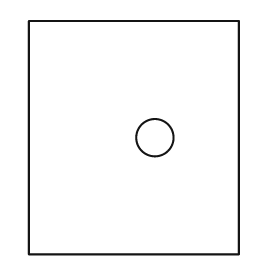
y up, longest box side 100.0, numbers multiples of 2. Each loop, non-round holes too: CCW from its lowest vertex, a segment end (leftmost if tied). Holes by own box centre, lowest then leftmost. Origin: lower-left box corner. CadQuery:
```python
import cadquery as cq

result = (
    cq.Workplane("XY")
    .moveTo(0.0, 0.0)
    .lineTo(90.0, 0.0)
    .lineTo(90.0, 100.0)
    .lineTo(0.0, 100.0)
    .close()
    .moveTo(54.0, 50.0)
    .circle(8.0)
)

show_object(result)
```